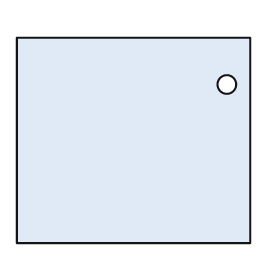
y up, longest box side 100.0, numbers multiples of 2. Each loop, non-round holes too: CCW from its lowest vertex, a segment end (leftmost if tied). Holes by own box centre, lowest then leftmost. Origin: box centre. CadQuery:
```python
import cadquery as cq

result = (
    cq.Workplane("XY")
    .moveTo(-50.0, -44.0)
    .lineTo(50.0, -44.0)
    .lineTo(50.0, 44.0)
    .lineTo(-50.0, 44.0)
    .close()
    .moveTo(40.0, 24.0)
    .circle(4.0)
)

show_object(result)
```